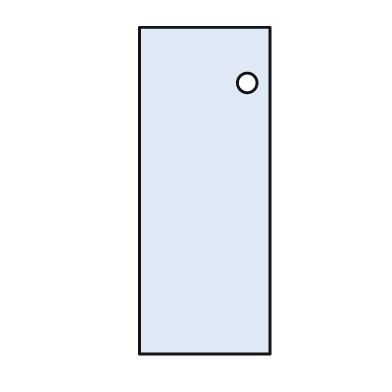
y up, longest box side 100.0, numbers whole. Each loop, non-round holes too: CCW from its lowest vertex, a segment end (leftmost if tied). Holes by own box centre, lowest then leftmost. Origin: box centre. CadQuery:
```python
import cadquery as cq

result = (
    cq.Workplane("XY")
    .moveTo(-20.0, -50.0)
    .lineTo(20.0, -50.0)
    .lineTo(20.0, 50.0)
    .lineTo(-20.0, 50.0)
    .close()
    .moveTo(13.0, 33.0)
    .circle(3.0)
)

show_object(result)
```